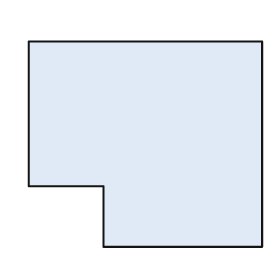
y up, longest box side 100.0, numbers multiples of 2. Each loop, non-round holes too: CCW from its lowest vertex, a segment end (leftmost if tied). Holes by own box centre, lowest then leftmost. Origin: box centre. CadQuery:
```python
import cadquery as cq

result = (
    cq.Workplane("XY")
    .moveTo(-18.0, -44.0)
    .lineTo(50.0, -44.0)
    .lineTo(50.0, 44.0)
    .lineTo(-50.0, 44.0)
    .lineTo(-50.0, -18.0)
    .lineTo(-18.0, -18.0)
    .close()
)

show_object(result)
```